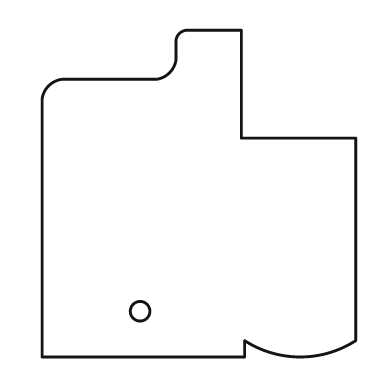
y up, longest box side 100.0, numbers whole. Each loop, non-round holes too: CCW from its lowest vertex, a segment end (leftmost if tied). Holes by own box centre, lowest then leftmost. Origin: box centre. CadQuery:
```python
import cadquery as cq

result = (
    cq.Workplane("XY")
    .moveTo(-48.0, -50.0)
    .lineTo(14.0, -50.0)
    .lineTo(14.0, -45.0)
    .threePointArc((31.0, -50.0), (48.0, -45.0))
    .lineTo(48.0, 17.0)
    .lineTo(13.0, 17.0)
    .lineTo(13.0, 50.0)
    .lineTo(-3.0, 50.0)
    .threePointArc((-6.0, 49.0), (-7.0, 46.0))
    .lineTo(-7.0, 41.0)
    .threePointArc((-9.0, 37.0), (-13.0, 35.0))
    .lineTo(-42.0, 35.0)
    .threePointArc((-46.0, 33.0), (-48.0, 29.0))
    .close()
    .moveTo(-18.0, -36.0)
    .circle(3.0)
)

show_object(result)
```